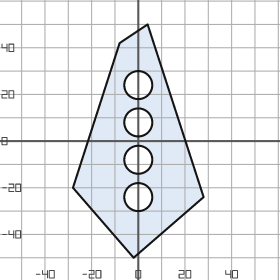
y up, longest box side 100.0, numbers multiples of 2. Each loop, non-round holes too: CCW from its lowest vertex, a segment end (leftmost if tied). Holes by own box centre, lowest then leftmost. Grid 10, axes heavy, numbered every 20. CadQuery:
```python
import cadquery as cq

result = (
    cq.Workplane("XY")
    .moveTo(-2.0, -50.0)
    .lineTo(28.0, -24.0)
    .lineTo(4.0, 50.0)
    .lineTo(-8.0, 42.0)
    .lineTo(-28.0, -20.0)
    .close()
    .moveTo(0.0, -24.0)
    .circle(6.0)
    .moveTo(0.0, -8.0)
    .circle(6.0)
    .moveTo(0.0, 8.0)
    .circle(6.0)
    .moveTo(0.0, 24.0)
    .circle(6.0)
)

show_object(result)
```